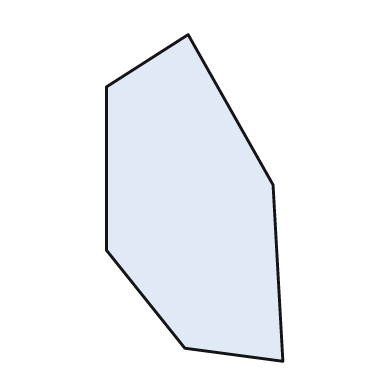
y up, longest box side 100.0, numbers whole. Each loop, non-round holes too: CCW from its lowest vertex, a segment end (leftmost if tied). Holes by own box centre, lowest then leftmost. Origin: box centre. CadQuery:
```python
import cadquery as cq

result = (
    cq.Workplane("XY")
    .moveTo(27.0, -50.0)
    .lineTo(24.0, 4.0)
    .lineTo(-2.0, 50.0)
    .lineTo(-27.0, 34.0)
    .lineTo(-27.0, -16.0)
    .lineTo(-3.0, -46.0)
    .close()
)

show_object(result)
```